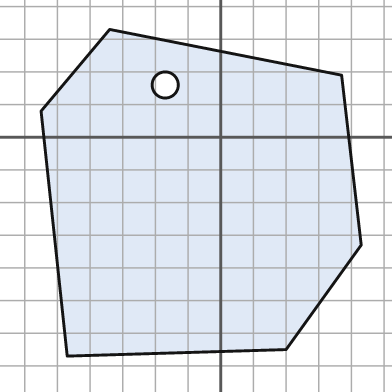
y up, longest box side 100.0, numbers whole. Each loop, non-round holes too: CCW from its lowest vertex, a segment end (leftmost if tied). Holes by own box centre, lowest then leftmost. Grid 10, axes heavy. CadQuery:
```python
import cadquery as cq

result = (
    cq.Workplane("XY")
    .moveTo(-47.0, -67.0)
    .lineTo(20.0, -65.0)
    .lineTo(43.0, -33.0)
    .lineTo(37.0, 19.0)
    .lineTo(-34.0, 33.0)
    .lineTo(-55.0, 8.0)
    .close()
    .moveTo(-17.0, 16.0)
    .circle(4.0)
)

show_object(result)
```